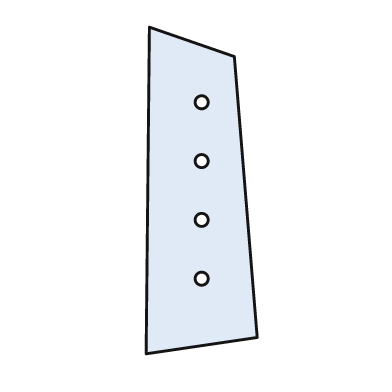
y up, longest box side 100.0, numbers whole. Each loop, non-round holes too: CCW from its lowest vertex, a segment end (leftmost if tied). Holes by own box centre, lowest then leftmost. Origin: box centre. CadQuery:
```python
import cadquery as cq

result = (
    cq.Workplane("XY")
    .moveTo(-17.0, -50.0)
    .lineTo(17.0, -45.0)
    .lineTo(10.0, 41.0)
    .lineTo(-16.0, 50.0)
    .close()
    .moveTo(0.0, -27.0)
    .circle(2.0)
    .moveTo(0.0, -9.0)
    .circle(2.0)
    .moveTo(0.0, 9.0)
    .circle(2.0)
    .moveTo(0.0, 27.0)
    .circle(2.0)
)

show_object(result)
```